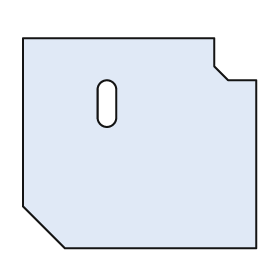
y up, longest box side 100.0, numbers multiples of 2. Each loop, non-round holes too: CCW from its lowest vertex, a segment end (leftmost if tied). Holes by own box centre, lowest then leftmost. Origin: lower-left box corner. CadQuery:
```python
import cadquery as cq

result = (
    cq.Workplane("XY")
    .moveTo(18.0, 0.0)
    .lineTo(100.0, 0.0)
    .lineTo(100.0, 72.0)
    .lineTo(88.0, 72.0)
    .lineTo(82.0, 78.0)
    .lineTo(82.0, 90.0)
    .lineTo(0.0, 90.0)
    .lineTo(0.0, 18.0)
    .close()
    .moveTo(32.0, 56.0)
    .threePointArc((36.0, 52.0), (40.0, 56.0))
    .lineTo(40.0, 68.0)
    .threePointArc((36.0, 72.0), (32.0, 68.0))
    .close()
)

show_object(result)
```